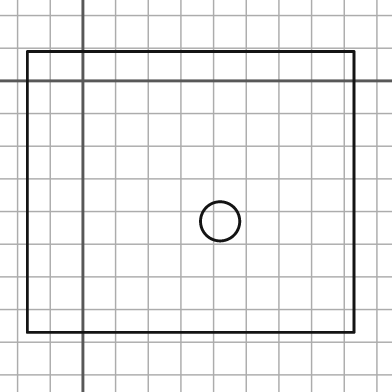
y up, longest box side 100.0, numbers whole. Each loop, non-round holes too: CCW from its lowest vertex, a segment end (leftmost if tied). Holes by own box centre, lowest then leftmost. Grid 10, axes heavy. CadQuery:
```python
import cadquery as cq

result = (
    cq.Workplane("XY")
    .moveTo(-17.0, -77.0)
    .lineTo(83.0, -77.0)
    .lineTo(83.0, 9.0)
    .lineTo(-17.0, 9.0)
    .close()
    .moveTo(42.0, -43.0)
    .circle(6.0)
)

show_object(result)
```